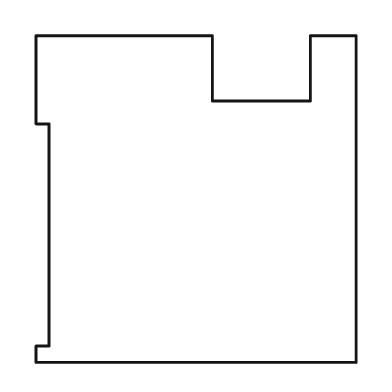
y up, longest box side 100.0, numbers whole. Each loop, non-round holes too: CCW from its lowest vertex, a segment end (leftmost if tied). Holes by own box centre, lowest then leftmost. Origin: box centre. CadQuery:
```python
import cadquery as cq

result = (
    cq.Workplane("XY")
    .moveTo(-49.0, -50.0)
    .lineTo(49.0, -50.0)
    .lineTo(49.0, 50.0)
    .lineTo(35.0, 50.0)
    .lineTo(35.0, 30.0)
    .lineTo(5.0, 30.0)
    .lineTo(5.0, 50.0)
    .lineTo(-49.0, 50.0)
    .lineTo(-49.0, 23.0)
    .lineTo(-45.0, 23.0)
    .lineTo(-45.0, -45.0)
    .lineTo(-49.0, -45.0)
    .close()
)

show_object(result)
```